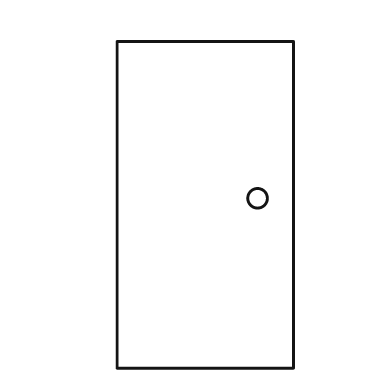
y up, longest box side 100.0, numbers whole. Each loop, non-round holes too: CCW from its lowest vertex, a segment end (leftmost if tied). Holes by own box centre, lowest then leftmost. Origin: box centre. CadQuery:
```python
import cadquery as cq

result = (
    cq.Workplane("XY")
    .moveTo(-27.0, -50.0)
    .lineTo(27.0, -50.0)
    .lineTo(27.0, 50.0)
    .lineTo(-27.0, 50.0)
    .close()
    .moveTo(16.0, 2.0)
    .circle(3.0)
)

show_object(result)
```